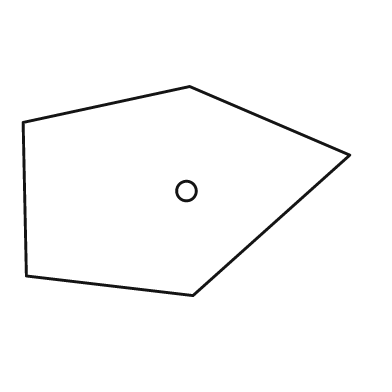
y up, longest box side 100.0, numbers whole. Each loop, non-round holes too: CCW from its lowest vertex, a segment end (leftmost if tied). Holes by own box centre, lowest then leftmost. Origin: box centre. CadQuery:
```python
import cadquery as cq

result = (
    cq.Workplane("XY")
    .moveTo(2.0, -32.0)
    .lineTo(50.0, 11.0)
    .lineTo(1.0, 32.0)
    .lineTo(-50.0, 21.0)
    .lineTo(-49.0, -26.0)
    .close()
    .moveTo(0.0, 0.0)
    .circle(3.0)
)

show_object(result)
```